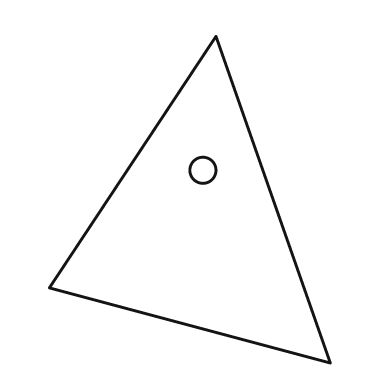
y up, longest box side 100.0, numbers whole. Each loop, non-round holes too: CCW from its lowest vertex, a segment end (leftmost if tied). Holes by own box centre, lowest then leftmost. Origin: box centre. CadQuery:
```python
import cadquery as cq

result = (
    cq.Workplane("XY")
    .moveTo(43.0, -50.0)
    .lineTo(8.0, 50.0)
    .lineTo(-43.0, -27.0)
    .close()
    .moveTo(4.0, 9.0)
    .circle(4.0)
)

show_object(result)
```